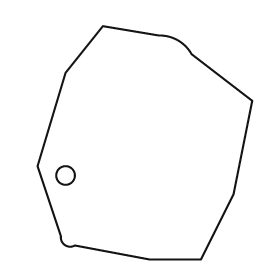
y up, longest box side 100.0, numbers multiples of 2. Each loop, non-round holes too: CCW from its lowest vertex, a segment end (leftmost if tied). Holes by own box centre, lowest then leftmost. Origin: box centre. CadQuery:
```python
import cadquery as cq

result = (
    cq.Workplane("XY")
    .moveTo(2.0, -50.0)
    .lineTo(24.0, -50.0)
    .lineTo(38.0, -22.0)
    .lineTo(46.0, 18.0)
    .lineTo(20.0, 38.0)
    .threePointArc((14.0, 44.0), (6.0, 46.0))
    .lineTo(-18.0, 50.0)
    .lineTo(-34.0, 30.0)
    .lineTo(-46.0, -10.0)
    .lineTo(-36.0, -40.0)
    .threePointArc((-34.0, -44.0), (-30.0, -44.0))
    .close()
    .moveTo(-34.0, -14.0)
    .circle(4.0)
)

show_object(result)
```